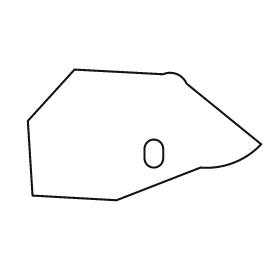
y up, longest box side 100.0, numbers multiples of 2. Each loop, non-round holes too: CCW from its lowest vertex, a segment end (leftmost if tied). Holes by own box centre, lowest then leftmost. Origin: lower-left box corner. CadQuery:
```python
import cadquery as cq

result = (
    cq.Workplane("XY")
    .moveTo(38.0, 0.0)
    .lineTo(74.0, 14.0)
    .threePointArc((88.0, 16.0), (100.0, 24.0))
    .lineTo(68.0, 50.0)
    .threePointArc((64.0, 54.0), (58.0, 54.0))
    .lineTo(20.0, 56.0)
    .lineTo(0.0, 34.0)
    .lineTo(2.0, 2.0)
    .close()
    .moveTo(50.0, 18.0)
    .threePointArc((54.0, 14.0), (58.0, 18.0))
    .lineTo(58.0, 22.0)
    .threePointArc((54.0, 26.0), (50.0, 22.0))
    .close()
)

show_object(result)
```